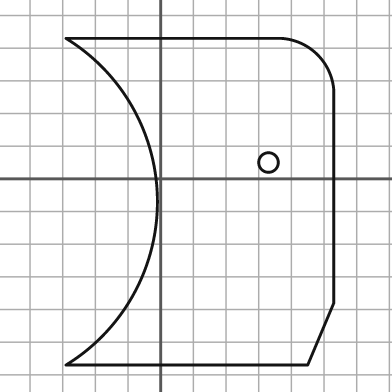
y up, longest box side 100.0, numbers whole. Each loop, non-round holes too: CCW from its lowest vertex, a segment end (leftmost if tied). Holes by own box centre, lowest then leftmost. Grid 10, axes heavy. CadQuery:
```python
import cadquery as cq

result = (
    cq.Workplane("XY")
    .moveTo(-29.0, -57.0)
    .lineTo(45.0, -57.0)
    .lineTo(53.0, -38.0)
    .lineTo(53.0, 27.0)
    .threePointArc((48.0, 38.0), (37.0, 43.0))
    .lineTo(-29.0, 43.0)
    .threePointArc((-1.0, -7.0), (-29.0, -57.0))
    .close()
    .moveTo(33.0, 5.0)
    .circle(3.0)
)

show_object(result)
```